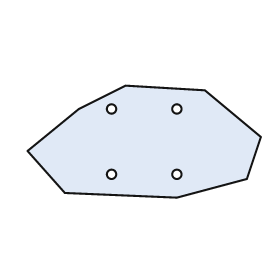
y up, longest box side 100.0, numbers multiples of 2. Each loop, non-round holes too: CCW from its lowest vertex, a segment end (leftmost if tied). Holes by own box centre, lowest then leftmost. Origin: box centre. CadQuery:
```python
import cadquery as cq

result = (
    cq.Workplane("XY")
    .moveTo(14.0, -24.0)
    .lineTo(44.0, -16.0)
    .lineTo(50.0, 2.0)
    .lineTo(26.0, 22.0)
    .lineTo(-8.0, 24.0)
    .lineTo(-28.0, 14.0)
    .lineTo(-50.0, -4.0)
    .lineTo(-34.0, -22.0)
    .close()
    .moveTo(-14.0, -14.0)
    .circle(2.0)
    .moveTo(14.0, -14.0)
    .circle(2.0)
    .moveTo(-14.0, 14.0)
    .circle(2.0)
    .moveTo(14.0, 14.0)
    .circle(2.0)
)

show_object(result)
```